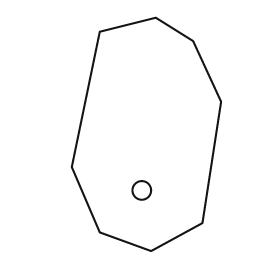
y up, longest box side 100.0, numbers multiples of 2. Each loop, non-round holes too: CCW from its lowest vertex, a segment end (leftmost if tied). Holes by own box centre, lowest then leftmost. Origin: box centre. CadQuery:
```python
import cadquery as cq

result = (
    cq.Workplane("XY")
    .moveTo(2.0, -50.0)
    .lineTo(24.0, -38.0)
    .lineTo(32.0, 14.0)
    .lineTo(20.0, 40.0)
    .lineTo(4.0, 50.0)
    .lineTo(-20.0, 44.0)
    .lineTo(-32.0, -14.0)
    .lineTo(-20.0, -42.0)
    .close()
    .moveTo(-2.0, -24.0)
    .circle(4.0)
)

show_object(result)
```